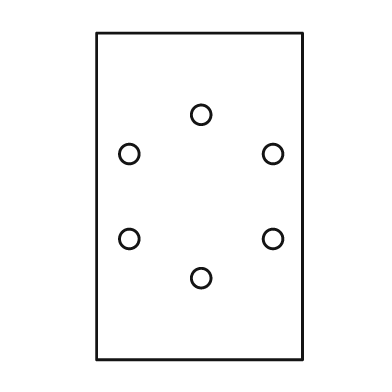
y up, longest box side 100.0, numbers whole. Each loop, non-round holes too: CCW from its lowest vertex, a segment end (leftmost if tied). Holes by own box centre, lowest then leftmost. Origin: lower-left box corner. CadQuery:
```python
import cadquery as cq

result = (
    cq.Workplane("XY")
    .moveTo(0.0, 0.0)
    .lineTo(63.0, 0.0)
    .lineTo(63.0, 100.0)
    .lineTo(0.0, 100.0)
    .close()
    .moveTo(32.0, 25.0)
    .circle(3.0)
    .moveTo(10.0, 37.0)
    .circle(3.0)
    .moveTo(54.0, 37.0)
    .circle(3.0)
    .moveTo(10.0, 63.0)
    .circle(3.0)
    .moveTo(54.0, 63.0)
    .circle(3.0)
    .moveTo(32.0, 75.0)
    .circle(3.0)
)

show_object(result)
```